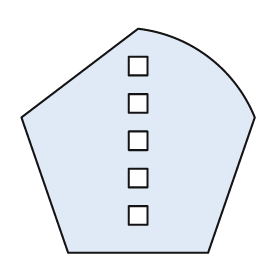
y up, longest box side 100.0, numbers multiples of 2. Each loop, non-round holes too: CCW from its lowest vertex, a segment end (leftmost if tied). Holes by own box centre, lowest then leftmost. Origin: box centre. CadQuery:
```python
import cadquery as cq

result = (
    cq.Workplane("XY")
    .moveTo(-30.0, -48.0)
    .lineTo(30.0, -48.0)
    .lineTo(50.0, 10.0)
    .threePointArc((30.0, 36.0), (0.0, 48.0))
    .lineTo(-50.0, 10.0)
    .close()
    .moveTo(-4.0, -36.0)
    .lineTo(4.0, -36.0)
    .lineTo(4.0, -28.0)
    .lineTo(-4.0, -28.0)
    .close()
    .moveTo(-4.0, -20.0)
    .lineTo(4.0, -20.0)
    .lineTo(4.0, -12.0)
    .lineTo(-4.0, -12.0)
    .close()
    .moveTo(-4.0, -4.0)
    .lineTo(4.0, -4.0)
    .lineTo(4.0, 4.0)
    .lineTo(-4.0, 4.0)
    .close()
    .moveTo(-4.0, 12.0)
    .lineTo(4.0, 12.0)
    .lineTo(4.0, 20.0)
    .lineTo(-4.0, 20.0)
    .close()
    .moveTo(-4.0, 28.0)
    .lineTo(4.0, 28.0)
    .lineTo(4.0, 36.0)
    .lineTo(-4.0, 36.0)
    .close()
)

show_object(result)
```